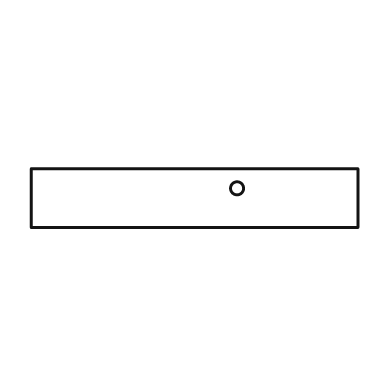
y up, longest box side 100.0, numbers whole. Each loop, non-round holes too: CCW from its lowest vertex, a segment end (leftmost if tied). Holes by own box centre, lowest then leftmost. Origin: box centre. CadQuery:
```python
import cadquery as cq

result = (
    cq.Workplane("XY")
    .moveTo(-50.0, -9.0)
    .lineTo(50.0, -9.0)
    .lineTo(50.0, 9.0)
    .lineTo(-50.0, 9.0)
    .close()
    .moveTo(13.0, 3.0)
    .circle(2.0)
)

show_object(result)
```